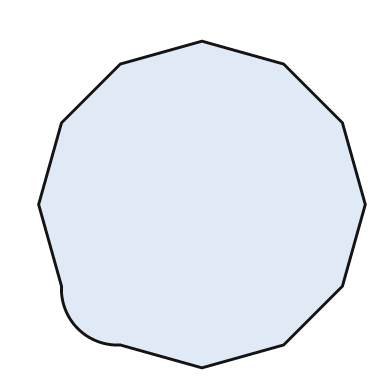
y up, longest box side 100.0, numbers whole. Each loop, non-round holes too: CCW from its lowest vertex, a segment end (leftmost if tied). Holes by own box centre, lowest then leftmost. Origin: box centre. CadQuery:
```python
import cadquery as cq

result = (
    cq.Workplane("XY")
    .moveTo(0.0, -50.0)
    .lineTo(25.0, -43.0)
    .lineTo(43.0, -25.0)
    .lineTo(50.0, 0.0)
    .lineTo(43.0, 25.0)
    .lineTo(25.0, 43.0)
    .lineTo(0.0, 50.0)
    .lineTo(-25.0, 43.0)
    .lineTo(-43.0, 25.0)
    .lineTo(-50.0, 0.0)
    .lineTo(-43.0, -25.0)
    .threePointArc((-38.0, -38.0), (-25.0, -43.0))
    .close()
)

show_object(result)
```